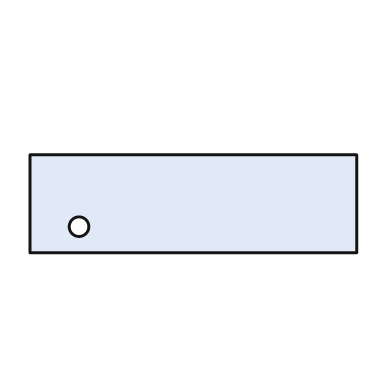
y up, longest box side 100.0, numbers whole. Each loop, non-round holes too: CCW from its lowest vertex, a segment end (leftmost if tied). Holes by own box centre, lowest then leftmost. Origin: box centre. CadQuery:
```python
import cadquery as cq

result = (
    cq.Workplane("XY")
    .moveTo(-50.0, -15.0)
    .lineTo(50.0, -15.0)
    .lineTo(50.0, 15.0)
    .lineTo(-50.0, 15.0)
    .close()
    .moveTo(-35.0, -7.0)
    .circle(3.0)
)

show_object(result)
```